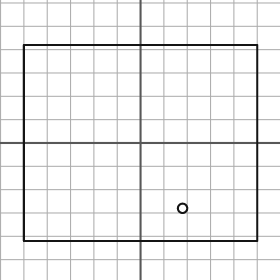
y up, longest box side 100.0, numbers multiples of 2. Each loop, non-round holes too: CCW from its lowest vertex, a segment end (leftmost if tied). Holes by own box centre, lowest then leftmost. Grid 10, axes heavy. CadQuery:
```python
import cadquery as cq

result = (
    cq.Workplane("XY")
    .moveTo(-50.0, -42.0)
    .lineTo(50.0, -42.0)
    .lineTo(50.0, 42.0)
    .lineTo(-50.0, 42.0)
    .close()
    .moveTo(18.0, -28.0)
    .circle(2.0)
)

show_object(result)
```